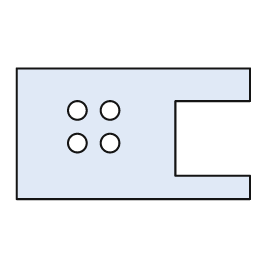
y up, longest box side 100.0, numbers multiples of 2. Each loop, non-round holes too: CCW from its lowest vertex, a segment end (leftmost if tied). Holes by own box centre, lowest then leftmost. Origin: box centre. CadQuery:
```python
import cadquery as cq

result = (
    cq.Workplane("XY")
    .moveTo(-50.0, -28.0)
    .lineTo(50.0, -28.0)
    .lineTo(50.0, -18.0)
    .lineTo(18.0, -18.0)
    .lineTo(18.0, 14.0)
    .lineTo(50.0, 14.0)
    .lineTo(50.0, 28.0)
    .lineTo(-50.0, 28.0)
    .close()
    .moveTo(-24.0, -4.0)
    .circle(4.0)
    .moveTo(-10.0, -4.0)
    .circle(4.0)
    .moveTo(-24.0, 10.0)
    .circle(4.0)
    .moveTo(-10.0, 10.0)
    .circle(4.0)
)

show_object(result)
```